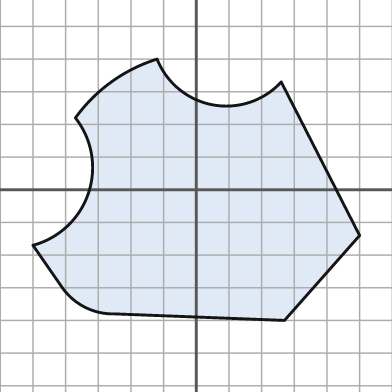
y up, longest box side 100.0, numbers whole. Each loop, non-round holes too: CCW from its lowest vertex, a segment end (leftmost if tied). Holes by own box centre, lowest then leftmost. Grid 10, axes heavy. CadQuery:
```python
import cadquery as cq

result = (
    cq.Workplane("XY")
    .moveTo(27.0, -40.0)
    .lineTo(50.0, -14.0)
    .lineTo(26.0, 33.0)
    .threePointArc((5.0, 26.0), (-12.0, 40.0))
    .threePointArc((-26.0, 33.0), (-37.0, 22.0))
    .threePointArc((-33.0, -1.0), (-50.0, -17.0))
    .lineTo(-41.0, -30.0)
    .threePointArc((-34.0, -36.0), (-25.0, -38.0))
    .close()
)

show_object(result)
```